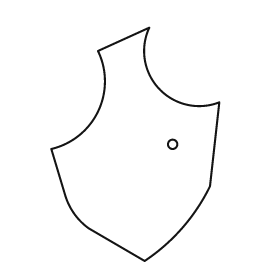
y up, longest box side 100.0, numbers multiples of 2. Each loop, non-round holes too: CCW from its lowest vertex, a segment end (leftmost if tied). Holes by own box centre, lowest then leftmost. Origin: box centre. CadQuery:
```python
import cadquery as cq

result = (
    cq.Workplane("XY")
    .moveTo(4.0, -50.0)
    .threePointArc((20.0, -36.0), (32.0, -18.0))
    .lineTo(36.0, 18.0)
    .threePointArc((10.0, 24.0), (6.0, 50.0))
    .lineTo(-16.0, 40.0)
    .threePointArc((-16.0, 14.0), (-36.0, -2.0))
    .lineTo(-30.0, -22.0)
    .threePointArc((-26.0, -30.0), (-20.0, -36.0))
    .close()
    .moveTo(16.0, 0.0)
    .circle(2.0)
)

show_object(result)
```